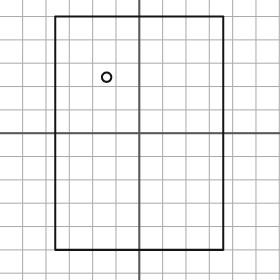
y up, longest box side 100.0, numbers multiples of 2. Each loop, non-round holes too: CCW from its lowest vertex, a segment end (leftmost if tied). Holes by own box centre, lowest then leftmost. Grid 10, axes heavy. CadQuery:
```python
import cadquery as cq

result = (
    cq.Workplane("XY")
    .moveTo(-36.0, -50.0)
    .lineTo(36.0, -50.0)
    .lineTo(36.0, 50.0)
    .lineTo(-36.0, 50.0)
    .close()
    .moveTo(-14.0, 24.0)
    .circle(2.0)
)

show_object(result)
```